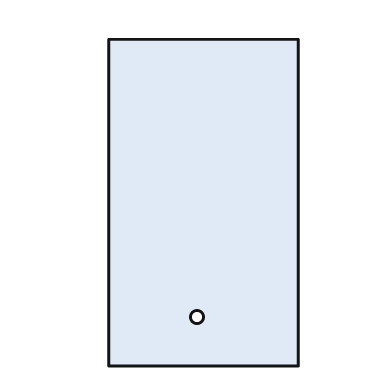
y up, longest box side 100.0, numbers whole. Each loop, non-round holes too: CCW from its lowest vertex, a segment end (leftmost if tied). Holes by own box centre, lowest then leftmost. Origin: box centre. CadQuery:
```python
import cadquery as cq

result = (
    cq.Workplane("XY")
    .moveTo(-29.0, -50.0)
    .lineTo(29.0, -50.0)
    .lineTo(29.0, 50.0)
    .lineTo(-29.0, 50.0)
    .close()
    .moveTo(-2.0, -35.0)
    .circle(2.0)
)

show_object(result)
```